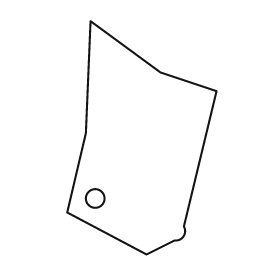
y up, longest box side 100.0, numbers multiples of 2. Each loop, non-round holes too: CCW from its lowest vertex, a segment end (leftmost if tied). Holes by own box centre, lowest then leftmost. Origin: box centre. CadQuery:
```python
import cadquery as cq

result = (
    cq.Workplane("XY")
    .moveTo(2.0, -50.0)
    .lineTo(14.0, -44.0)
    .threePointArc((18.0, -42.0), (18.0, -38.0))
    .lineTo(32.0, 20.0)
    .lineTo(8.0, 28.0)
    .lineTo(-22.0, 50.0)
    .lineTo(-24.0, 2.0)
    .lineTo(-32.0, -32.0)
    .close()
    .moveTo(-20.0, -26.0)
    .circle(4.0)
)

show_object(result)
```